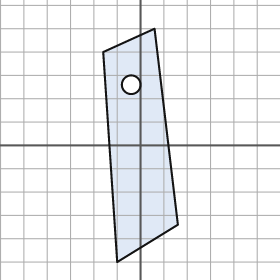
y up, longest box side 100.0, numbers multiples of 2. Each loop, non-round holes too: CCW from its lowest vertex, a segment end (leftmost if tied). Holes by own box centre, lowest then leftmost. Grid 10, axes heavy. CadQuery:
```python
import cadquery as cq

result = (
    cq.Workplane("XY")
    .moveTo(-10.0, -50.0)
    .lineTo(16.0, -34.0)
    .lineTo(6.0, 50.0)
    .lineTo(-16.0, 40.0)
    .close()
    .moveTo(-4.0, 26.0)
    .circle(4.0)
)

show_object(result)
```